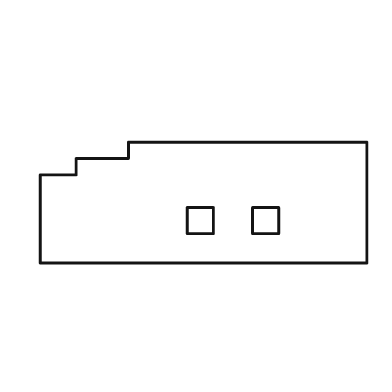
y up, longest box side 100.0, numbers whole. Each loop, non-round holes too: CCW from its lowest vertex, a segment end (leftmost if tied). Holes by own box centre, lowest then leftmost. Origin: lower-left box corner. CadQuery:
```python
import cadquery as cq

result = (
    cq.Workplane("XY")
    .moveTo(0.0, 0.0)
    .lineTo(100.0, 0.0)
    .lineTo(100.0, 37.0)
    .lineTo(27.0, 37.0)
    .lineTo(27.0, 32.0)
    .lineTo(11.0, 32.0)
    .lineTo(11.0, 27.0)
    .lineTo(0.0, 27.0)
    .close()
    .moveTo(45.0, 9.0)
    .lineTo(53.0, 9.0)
    .lineTo(53.0, 17.0)
    .lineTo(45.0, 17.0)
    .close()
    .moveTo(65.0, 9.0)
    .lineTo(73.0, 9.0)
    .lineTo(73.0, 17.0)
    .lineTo(65.0, 17.0)
    .close()
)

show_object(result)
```